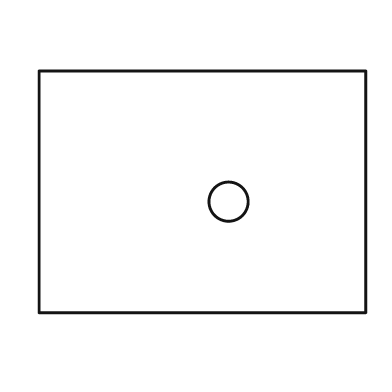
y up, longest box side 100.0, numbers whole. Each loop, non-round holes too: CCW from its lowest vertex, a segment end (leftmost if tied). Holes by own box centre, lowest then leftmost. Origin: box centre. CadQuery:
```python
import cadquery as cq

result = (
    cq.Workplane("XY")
    .moveTo(-50.0, -37.0)
    .lineTo(50.0, -37.0)
    .lineTo(50.0, 37.0)
    .lineTo(-50.0, 37.0)
    .close()
    .moveTo(8.0, -3.0)
    .circle(6.0)
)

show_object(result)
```